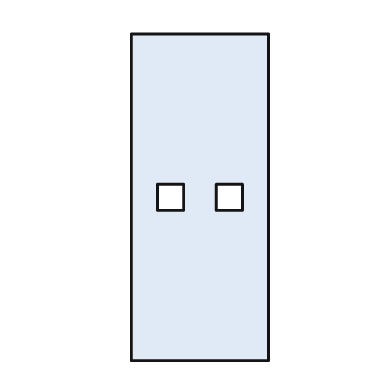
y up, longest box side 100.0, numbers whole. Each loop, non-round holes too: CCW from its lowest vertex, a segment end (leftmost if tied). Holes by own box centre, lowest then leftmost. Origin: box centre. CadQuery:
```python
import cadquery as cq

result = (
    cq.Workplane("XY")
    .moveTo(-21.0, -50.0)
    .lineTo(21.0, -50.0)
    .lineTo(21.0, 50.0)
    .lineTo(-21.0, 50.0)
    .close()
    .moveTo(-13.0, -4.0)
    .lineTo(-5.0, -4.0)
    .lineTo(-5.0, 4.0)
    .lineTo(-13.0, 4.0)
    .close()
    .moveTo(5.0, -4.0)
    .lineTo(13.0, -4.0)
    .lineTo(13.0, 4.0)
    .lineTo(5.0, 4.0)
    .close()
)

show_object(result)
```